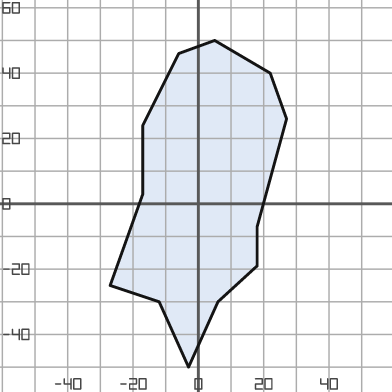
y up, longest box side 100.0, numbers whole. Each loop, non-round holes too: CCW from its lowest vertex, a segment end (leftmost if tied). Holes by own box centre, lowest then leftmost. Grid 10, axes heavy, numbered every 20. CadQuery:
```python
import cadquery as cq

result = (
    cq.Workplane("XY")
    .moveTo(-3.0, -50.0)
    .lineTo(6.0, -30.0)
    .lineTo(18.0, -19.0)
    .lineTo(18.0, -7.0)
    .lineTo(27.0, 26.0)
    .lineTo(22.0, 40.0)
    .lineTo(5.0, 50.0)
    .lineTo(-6.0, 46.0)
    .lineTo(-17.0, 24.0)
    .lineTo(-17.0, 3.0)
    .lineTo(-27.0, -25.0)
    .lineTo(-12.0, -30.0)
    .close()
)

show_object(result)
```